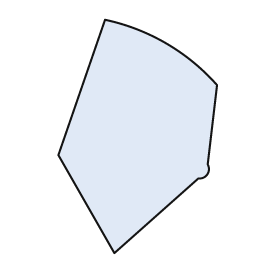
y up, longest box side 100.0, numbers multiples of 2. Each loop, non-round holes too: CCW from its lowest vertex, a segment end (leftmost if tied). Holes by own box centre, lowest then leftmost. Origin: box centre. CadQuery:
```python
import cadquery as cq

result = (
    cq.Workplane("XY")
    .moveTo(-10.0, -50.0)
    .lineTo(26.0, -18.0)
    .threePointArc((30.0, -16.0), (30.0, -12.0))
    .lineTo(34.0, 22.0)
    .threePointArc((12.0, 40.0), (-14.0, 50.0))
    .lineTo(-34.0, -8.0)
    .close()
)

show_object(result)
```